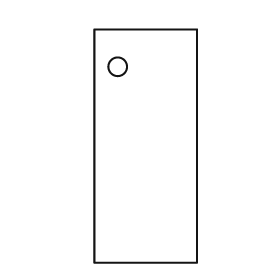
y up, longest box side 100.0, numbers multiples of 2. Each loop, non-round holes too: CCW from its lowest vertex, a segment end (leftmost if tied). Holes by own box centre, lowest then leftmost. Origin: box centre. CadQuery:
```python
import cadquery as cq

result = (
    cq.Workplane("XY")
    .moveTo(-22.0, -50.0)
    .lineTo(22.0, -50.0)
    .lineTo(22.0, 50.0)
    .lineTo(-22.0, 50.0)
    .close()
    .moveTo(-12.0, 34.0)
    .circle(4.0)
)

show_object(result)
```